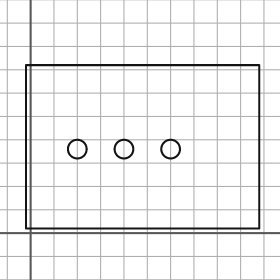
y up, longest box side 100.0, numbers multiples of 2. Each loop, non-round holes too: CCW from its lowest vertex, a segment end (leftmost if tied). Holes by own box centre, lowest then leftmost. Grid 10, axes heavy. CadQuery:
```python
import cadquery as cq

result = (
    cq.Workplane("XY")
    .moveTo(-2.0, 2.0)
    .lineTo(98.0, 2.0)
    .lineTo(98.0, 72.0)
    .lineTo(-2.0, 72.0)
    .close()
    .moveTo(20.0, 36.0)
    .circle(4.0)
    .moveTo(40.0, 36.0)
    .circle(4.0)
    .moveTo(60.0, 36.0)
    .circle(4.0)
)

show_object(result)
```